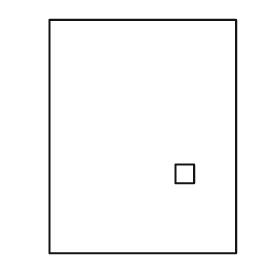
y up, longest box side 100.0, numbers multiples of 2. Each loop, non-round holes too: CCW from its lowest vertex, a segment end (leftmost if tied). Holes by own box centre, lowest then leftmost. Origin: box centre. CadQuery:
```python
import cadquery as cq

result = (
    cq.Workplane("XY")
    .moveTo(-40.0, -50.0)
    .lineTo(40.0, -50.0)
    .lineTo(40.0, 50.0)
    .lineTo(-40.0, 50.0)
    .close()
    .moveTo(14.0, -20.0)
    .lineTo(22.0, -20.0)
    .lineTo(22.0, -12.0)
    .lineTo(14.0, -12.0)
    .close()
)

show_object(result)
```